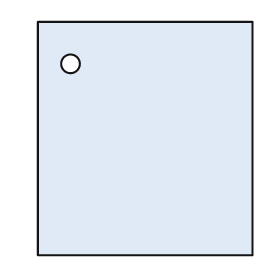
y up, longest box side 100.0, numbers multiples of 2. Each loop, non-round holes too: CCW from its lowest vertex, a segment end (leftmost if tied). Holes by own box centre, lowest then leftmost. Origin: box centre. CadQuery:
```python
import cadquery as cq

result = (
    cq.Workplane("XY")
    .moveTo(-46.0, -50.0)
    .lineTo(46.0, -50.0)
    .lineTo(46.0, 50.0)
    .lineTo(-46.0, 50.0)
    .close()
    .moveTo(-32.0, 32.0)
    .circle(4.0)
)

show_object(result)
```